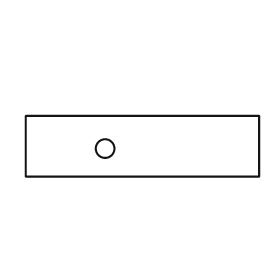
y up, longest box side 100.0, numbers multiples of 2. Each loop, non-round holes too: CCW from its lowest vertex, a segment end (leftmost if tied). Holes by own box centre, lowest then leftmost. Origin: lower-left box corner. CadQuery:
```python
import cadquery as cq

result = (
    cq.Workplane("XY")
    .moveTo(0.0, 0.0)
    .lineTo(100.0, 0.0)
    .lineTo(100.0, 26.0)
    .lineTo(0.0, 26.0)
    .close()
    .moveTo(34.0, 12.0)
    .circle(4.0)
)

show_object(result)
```